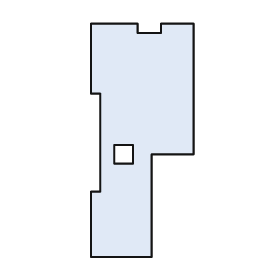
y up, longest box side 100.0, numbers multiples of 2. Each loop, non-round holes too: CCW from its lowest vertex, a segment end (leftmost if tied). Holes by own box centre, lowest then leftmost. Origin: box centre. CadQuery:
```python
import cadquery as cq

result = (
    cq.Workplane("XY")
    .moveTo(-22.0, -50.0)
    .lineTo(4.0, -50.0)
    .lineTo(4.0, -6.0)
    .lineTo(22.0, -6.0)
    .lineTo(22.0, 50.0)
    .lineTo(8.0, 50.0)
    .lineTo(8.0, 46.0)
    .lineTo(-2.0, 46.0)
    .lineTo(-2.0, 50.0)
    .lineTo(-22.0, 50.0)
    .lineTo(-22.0, 20.0)
    .lineTo(-18.0, 20.0)
    .lineTo(-18.0, -22.0)
    .lineTo(-22.0, -22.0)
    .close()
    .moveTo(-12.0, -10.0)
    .lineTo(-4.0, -10.0)
    .lineTo(-4.0, -2.0)
    .lineTo(-12.0, -2.0)
    .close()
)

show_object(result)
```